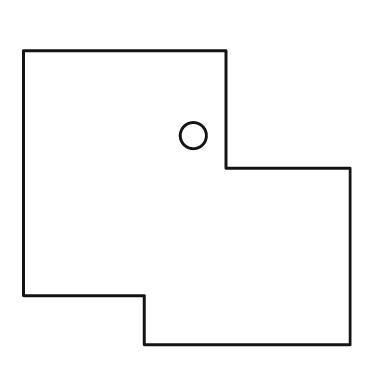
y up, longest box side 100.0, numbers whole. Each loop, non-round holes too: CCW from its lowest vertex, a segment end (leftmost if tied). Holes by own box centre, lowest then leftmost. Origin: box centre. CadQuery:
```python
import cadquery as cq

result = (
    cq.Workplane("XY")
    .moveTo(-13.0, -45.0)
    .lineTo(50.0, -45.0)
    .lineTo(50.0, 9.0)
    .lineTo(12.0, 9.0)
    .lineTo(12.0, 45.0)
    .lineTo(-50.0, 45.0)
    .lineTo(-50.0, -30.0)
    .lineTo(-13.0, -30.0)
    .close()
    .moveTo(2.0, 19.0)
    .circle(4.0)
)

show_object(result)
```